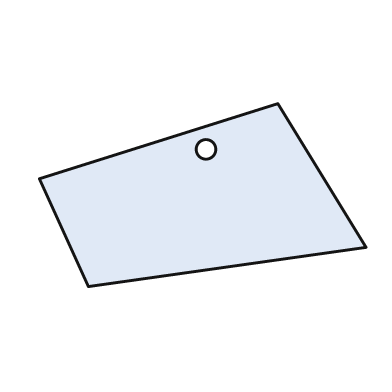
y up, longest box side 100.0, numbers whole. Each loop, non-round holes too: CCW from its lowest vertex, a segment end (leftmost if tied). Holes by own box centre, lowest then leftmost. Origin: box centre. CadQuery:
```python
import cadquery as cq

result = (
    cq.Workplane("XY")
    .moveTo(-35.0, -28.0)
    .lineTo(50.0, -16.0)
    .lineTo(23.0, 28.0)
    .lineTo(-50.0, 5.0)
    .close()
    .moveTo(1.0, 14.0)
    .circle(3.0)
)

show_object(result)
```